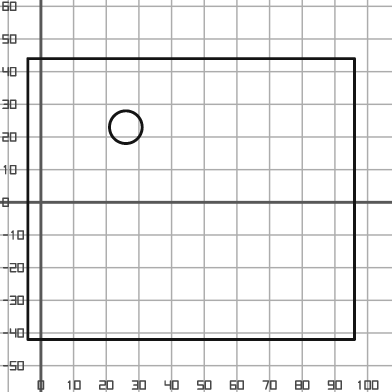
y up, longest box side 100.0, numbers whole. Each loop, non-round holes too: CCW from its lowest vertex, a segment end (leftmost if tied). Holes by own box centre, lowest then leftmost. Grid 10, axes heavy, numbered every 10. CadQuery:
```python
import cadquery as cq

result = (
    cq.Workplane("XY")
    .moveTo(-4.0, -42.0)
    .lineTo(96.0, -42.0)
    .lineTo(96.0, 44.0)
    .lineTo(-4.0, 44.0)
    .close()
    .moveTo(26.0, 23.0)
    .circle(5.0)
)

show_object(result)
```